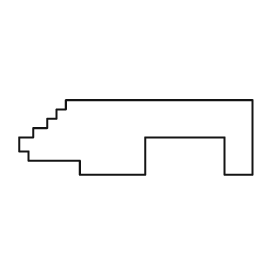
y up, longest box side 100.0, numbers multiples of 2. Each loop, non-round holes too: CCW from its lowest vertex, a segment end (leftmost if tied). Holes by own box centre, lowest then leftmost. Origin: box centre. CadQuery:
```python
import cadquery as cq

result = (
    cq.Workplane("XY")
    .moveTo(-24.0, -16.0)
    .lineTo(4.0, -16.0)
    .lineTo(4.0, 0.0)
    .lineTo(38.0, 0.0)
    .lineTo(38.0, -16.0)
    .lineTo(50.0, -16.0)
    .lineTo(50.0, 16.0)
    .lineTo(-30.0, 16.0)
    .lineTo(-30.0, 12.0)
    .lineTo(-34.0, 12.0)
    .lineTo(-34.0, 8.0)
    .lineTo(-38.0, 8.0)
    .lineTo(-38.0, 4.0)
    .lineTo(-44.0, 4.0)
    .lineTo(-44.0, 0.0)
    .lineTo(-50.0, 0.0)
    .lineTo(-50.0, -6.0)
    .lineTo(-46.0, -6.0)
    .lineTo(-46.0, -10.0)
    .lineTo(-24.0, -10.0)
    .close()
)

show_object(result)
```